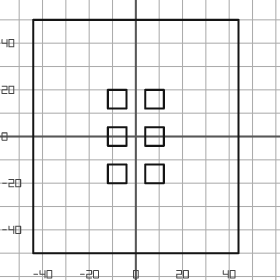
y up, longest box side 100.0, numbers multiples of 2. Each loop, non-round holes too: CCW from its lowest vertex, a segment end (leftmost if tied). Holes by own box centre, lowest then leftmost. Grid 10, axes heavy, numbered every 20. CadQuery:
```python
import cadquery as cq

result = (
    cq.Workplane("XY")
    .moveTo(-44.0, -50.0)
    .lineTo(44.0, -50.0)
    .lineTo(44.0, 50.0)
    .lineTo(-44.0, 50.0)
    .close()
    .moveTo(-12.0, -20.0)
    .lineTo(-4.0, -20.0)
    .lineTo(-4.0, -12.0)
    .lineTo(-12.0, -12.0)
    .close()
    .moveTo(4.0, -20.0)
    .lineTo(12.0, -20.0)
    .lineTo(12.0, -12.0)
    .lineTo(4.0, -12.0)
    .close()
    .moveTo(-12.0, -4.0)
    .lineTo(-4.0, -4.0)
    .lineTo(-4.0, 4.0)
    .lineTo(-12.0, 4.0)
    .close()
    .moveTo(4.0, -4.0)
    .lineTo(12.0, -4.0)
    .lineTo(12.0, 4.0)
    .lineTo(4.0, 4.0)
    .close()
    .moveTo(-12.0, 12.0)
    .lineTo(-4.0, 12.0)
    .lineTo(-4.0, 20.0)
    .lineTo(-12.0, 20.0)
    .close()
    .moveTo(4.0, 12.0)
    .lineTo(12.0, 12.0)
    .lineTo(12.0, 20.0)
    .lineTo(4.0, 20.0)
    .close()
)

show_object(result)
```